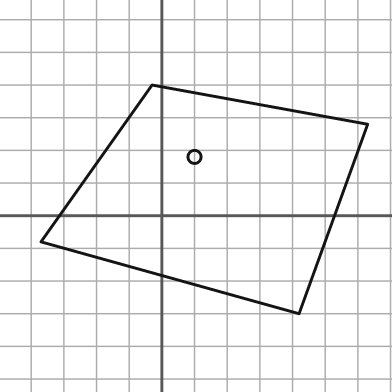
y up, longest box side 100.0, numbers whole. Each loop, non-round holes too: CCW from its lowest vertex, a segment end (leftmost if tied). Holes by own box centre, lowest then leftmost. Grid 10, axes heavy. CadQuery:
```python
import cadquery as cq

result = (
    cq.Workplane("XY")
    .moveTo(42.0, -30.0)
    .lineTo(63.0, 28.0)
    .lineTo(-3.0, 40.0)
    .lineTo(-37.0, -8.0)
    .close()
    .moveTo(10.0, 18.0)
    .circle(2.0)
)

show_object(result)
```